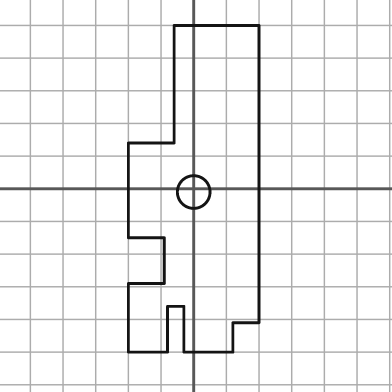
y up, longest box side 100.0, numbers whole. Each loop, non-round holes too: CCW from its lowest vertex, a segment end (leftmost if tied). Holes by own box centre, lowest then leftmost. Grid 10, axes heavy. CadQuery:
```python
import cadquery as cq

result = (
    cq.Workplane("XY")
    .moveTo(-20.0, -50.0)
    .lineTo(-8.0, -50.0)
    .lineTo(-8.0, -36.0)
    .lineTo(-3.0, -36.0)
    .lineTo(-3.0, -50.0)
    .lineTo(12.0, -50.0)
    .lineTo(12.0, -41.0)
    .lineTo(20.0, -41.0)
    .lineTo(20.0, 50.0)
    .lineTo(-6.0, 50.0)
    .lineTo(-6.0, 14.0)
    .lineTo(-20.0, 14.0)
    .lineTo(-20.0, -15.0)
    .lineTo(-9.0, -15.0)
    .lineTo(-9.0, -29.0)
    .lineTo(-20.0, -29.0)
    .close()
    .moveTo(0.0, -1.0)
    .circle(5.0)
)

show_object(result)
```